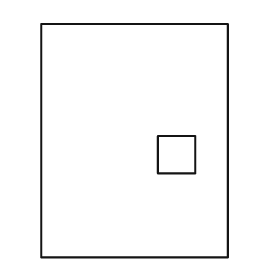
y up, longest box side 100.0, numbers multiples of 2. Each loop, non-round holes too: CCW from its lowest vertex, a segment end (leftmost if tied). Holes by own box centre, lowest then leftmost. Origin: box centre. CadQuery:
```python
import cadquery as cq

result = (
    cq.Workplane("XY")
    .moveTo(-40.0, -50.0)
    .lineTo(40.0, -50.0)
    .lineTo(40.0, 50.0)
    .lineTo(-40.0, 50.0)
    .close()
    .moveTo(10.0, -14.0)
    .lineTo(26.0, -14.0)
    .lineTo(26.0, 2.0)
    .lineTo(10.0, 2.0)
    .close()
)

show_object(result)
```